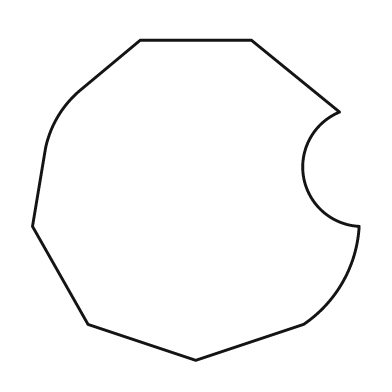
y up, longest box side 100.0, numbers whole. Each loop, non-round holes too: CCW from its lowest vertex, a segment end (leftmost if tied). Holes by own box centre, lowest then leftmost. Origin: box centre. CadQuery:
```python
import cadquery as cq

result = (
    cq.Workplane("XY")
    .moveTo(0.0, -49.0)
    .lineTo(33.0, -38.0)
    .threePointArc((45.0, -25.0), (50.0, -8.0))
    .threePointArc((33.0, 7.0), (44.0, 27.0))
    .lineTo(17.0, 49.0)
    .lineTo(-17.0, 49.0)
    .lineTo(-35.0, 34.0)
    .threePointArc((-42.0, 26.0), (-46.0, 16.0))
    .lineTo(-50.0, -8.0)
    .lineTo(-33.0, -38.0)
    .close()
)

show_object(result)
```